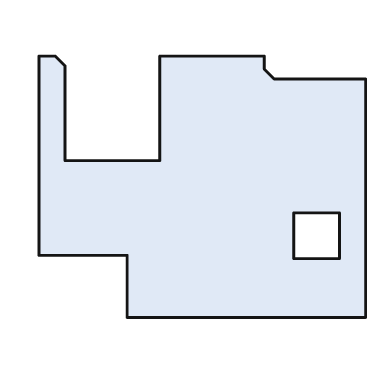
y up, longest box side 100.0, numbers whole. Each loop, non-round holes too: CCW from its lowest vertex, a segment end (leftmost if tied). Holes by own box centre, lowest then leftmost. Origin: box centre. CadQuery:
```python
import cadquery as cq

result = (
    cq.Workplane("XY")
    .moveTo(-23.0, -40.0)
    .lineTo(50.0, -40.0)
    .lineTo(50.0, 33.0)
    .lineTo(22.0, 33.0)
    .lineTo(19.0, 36.0)
    .lineTo(19.0, 40.0)
    .lineTo(-13.0, 40.0)
    .lineTo(-13.0, 8.0)
    .lineTo(-42.0, 8.0)
    .lineTo(-42.0, 37.0)
    .lineTo(-45.0, 40.0)
    .lineTo(-50.0, 40.0)
    .lineTo(-50.0, -21.0)
    .lineTo(-23.0, -21.0)
    .close()
    .moveTo(28.0, -22.0)
    .lineTo(42.0, -22.0)
    .lineTo(42.0, -8.0)
    .lineTo(28.0, -8.0)
    .close()
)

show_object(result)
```